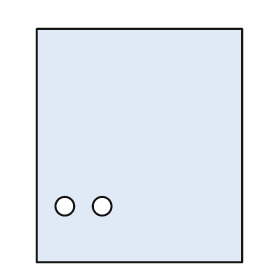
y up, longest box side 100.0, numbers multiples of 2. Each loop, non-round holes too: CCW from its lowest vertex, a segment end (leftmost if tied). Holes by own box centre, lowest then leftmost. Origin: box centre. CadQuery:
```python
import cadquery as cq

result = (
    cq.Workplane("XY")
    .moveTo(-44.0, -50.0)
    .lineTo(44.0, -50.0)
    .lineTo(44.0, 50.0)
    .lineTo(-44.0, 50.0)
    .close()
    .moveTo(-32.0, -26.0)
    .circle(4.0)
    .moveTo(-16.0, -26.0)
    .circle(4.0)
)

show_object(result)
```